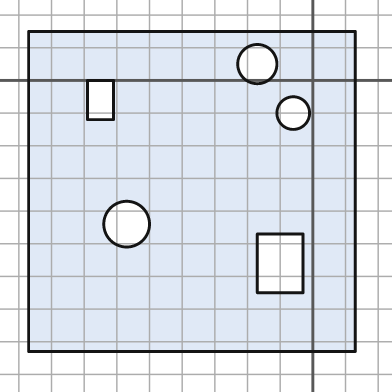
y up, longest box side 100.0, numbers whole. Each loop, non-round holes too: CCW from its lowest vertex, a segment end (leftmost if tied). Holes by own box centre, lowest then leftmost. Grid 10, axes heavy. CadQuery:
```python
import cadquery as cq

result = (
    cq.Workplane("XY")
    .moveTo(-87.0, -83.0)
    .lineTo(13.0, -83.0)
    .lineTo(13.0, 15.0)
    .lineTo(-87.0, 15.0)
    .close()
    .moveTo(-17.0, -65.0)
    .lineTo(-3.0, -65.0)
    .lineTo(-3.0, -47.0)
    .lineTo(-17.0, -47.0)
    .close()
    .moveTo(-57.0, -44.0)
    .circle(7.0)
    .moveTo(-6.0, -10.0)
    .circle(5.0)
    .moveTo(-69.0, -12.0)
    .lineTo(-61.0, -12.0)
    .lineTo(-61.0, 0.0)
    .lineTo(-69.0, 0.0)
    .close()
    .moveTo(-17.0, 5.0)
    .circle(6.0)
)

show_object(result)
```